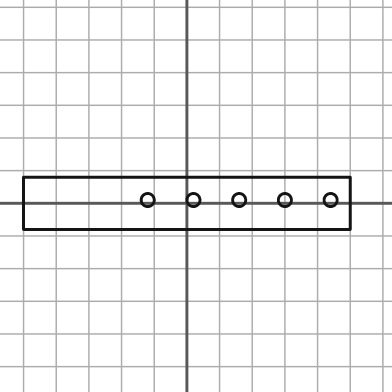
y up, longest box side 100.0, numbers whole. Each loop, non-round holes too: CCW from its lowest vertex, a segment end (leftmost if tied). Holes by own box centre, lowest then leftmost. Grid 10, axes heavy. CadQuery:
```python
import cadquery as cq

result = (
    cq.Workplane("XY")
    .moveTo(-50.0, -8.0)
    .lineTo(50.0, -8.0)
    .lineTo(50.0, 8.0)
    .lineTo(-50.0, 8.0)
    .close()
    .moveTo(-12.0, 1.0)
    .circle(2.0)
    .moveTo(2.0, 1.0)
    .circle(2.0)
    .moveTo(16.0, 1.0)
    .circle(2.0)
    .moveTo(30.0, 1.0)
    .circle(2.0)
    .moveTo(44.0, 1.0)
    .circle(2.0)
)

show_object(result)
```